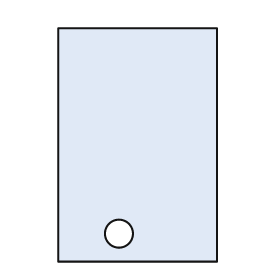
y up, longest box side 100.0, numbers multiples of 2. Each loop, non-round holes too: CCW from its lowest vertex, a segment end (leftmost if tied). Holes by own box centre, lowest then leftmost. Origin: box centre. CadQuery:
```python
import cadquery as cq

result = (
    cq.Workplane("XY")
    .moveTo(-34.0, -50.0)
    .lineTo(34.0, -50.0)
    .lineTo(34.0, 50.0)
    .lineTo(-34.0, 50.0)
    .close()
    .moveTo(-8.0, -38.0)
    .circle(6.0)
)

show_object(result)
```